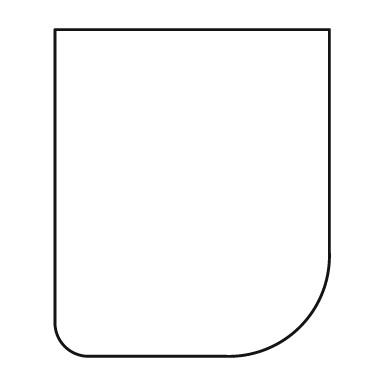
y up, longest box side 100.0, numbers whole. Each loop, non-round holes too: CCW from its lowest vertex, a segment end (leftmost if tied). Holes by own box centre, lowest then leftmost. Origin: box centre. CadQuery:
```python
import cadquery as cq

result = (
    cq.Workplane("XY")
    .moveTo(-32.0, -50.0)
    .lineTo(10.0, -50.0)
    .threePointArc((33.0, -41.0), (42.0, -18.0))
    .lineTo(42.0, 50.0)
    .lineTo(-42.0, 50.0)
    .lineTo(-42.0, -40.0)
    .threePointArc((-39.0, -47.0), (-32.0, -50.0))
    .close()
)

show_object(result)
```